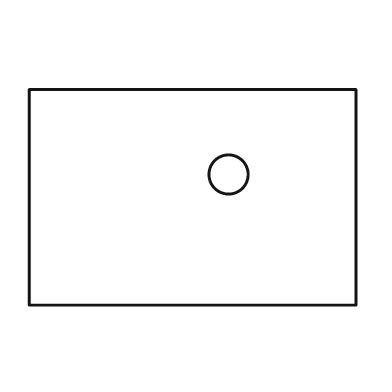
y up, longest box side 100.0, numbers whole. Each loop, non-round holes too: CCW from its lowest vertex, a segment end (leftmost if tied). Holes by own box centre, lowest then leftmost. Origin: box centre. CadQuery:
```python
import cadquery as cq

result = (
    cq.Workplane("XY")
    .moveTo(-50.0, -33.0)
    .lineTo(50.0, -33.0)
    .lineTo(50.0, 33.0)
    .lineTo(-50.0, 33.0)
    .close()
    .moveTo(11.0, 7.0)
    .circle(6.0)
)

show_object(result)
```